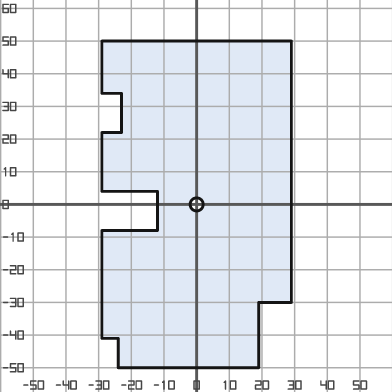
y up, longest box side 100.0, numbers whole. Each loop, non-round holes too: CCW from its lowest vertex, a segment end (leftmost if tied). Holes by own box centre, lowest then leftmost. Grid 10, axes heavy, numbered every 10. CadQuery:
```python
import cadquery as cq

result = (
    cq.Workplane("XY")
    .moveTo(-24.0, -50.0)
    .lineTo(19.0, -50.0)
    .lineTo(19.0, -30.0)
    .lineTo(29.0, -30.0)
    .lineTo(29.0, 50.0)
    .lineTo(-29.0, 50.0)
    .lineTo(-29.0, 34.0)
    .lineTo(-23.0, 34.0)
    .lineTo(-23.0, 22.0)
    .lineTo(-29.0, 22.0)
    .lineTo(-29.0, 4.0)
    .lineTo(-12.0, 4.0)
    .lineTo(-12.0, -8.0)
    .lineTo(-29.0, -8.0)
    .lineTo(-29.0, -41.0)
    .lineTo(-24.0, -41.0)
    .close()
    .moveTo(0.0, 0.0)
    .circle(2.0)
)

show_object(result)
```